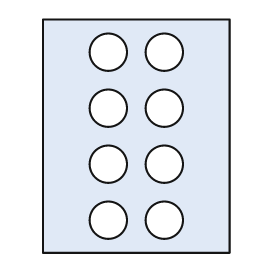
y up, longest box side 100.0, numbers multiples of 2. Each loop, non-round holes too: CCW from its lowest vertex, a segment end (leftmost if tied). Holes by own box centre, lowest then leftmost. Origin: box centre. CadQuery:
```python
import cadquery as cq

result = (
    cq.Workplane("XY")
    .moveTo(-40.0, -50.0)
    .lineTo(40.0, -50.0)
    .lineTo(40.0, 50.0)
    .lineTo(-40.0, 50.0)
    .close()
    .moveTo(-12.0, -36.0)
    .circle(8.0)
    .moveTo(12.0, -36.0)
    .circle(8.0)
    .moveTo(-12.0, -12.0)
    .circle(8.0)
    .moveTo(12.0, -12.0)
    .circle(8.0)
    .moveTo(-12.0, 12.0)
    .circle(8.0)
    .moveTo(12.0, 12.0)
    .circle(8.0)
    .moveTo(-12.0, 36.0)
    .circle(8.0)
    .moveTo(12.0, 36.0)
    .circle(8.0)
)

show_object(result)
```